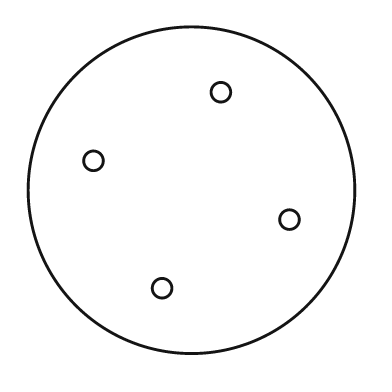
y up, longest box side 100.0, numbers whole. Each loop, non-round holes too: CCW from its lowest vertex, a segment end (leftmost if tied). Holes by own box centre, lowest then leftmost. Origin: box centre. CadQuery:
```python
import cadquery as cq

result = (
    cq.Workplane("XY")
    .moveTo(0.0, 0.0)
    .circle(50.0)
    .moveTo(-9.0, -30.0)
    .circle(3.0)
    .moveTo(30.0, -9.0)
    .circle(3.0)
    .moveTo(-30.0, 9.0)
    .circle(3.0)
    .moveTo(9.0, 30.0)
    .circle(3.0)
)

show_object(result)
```